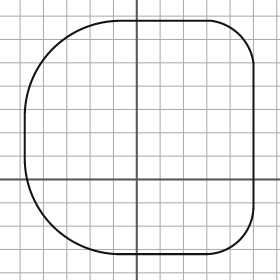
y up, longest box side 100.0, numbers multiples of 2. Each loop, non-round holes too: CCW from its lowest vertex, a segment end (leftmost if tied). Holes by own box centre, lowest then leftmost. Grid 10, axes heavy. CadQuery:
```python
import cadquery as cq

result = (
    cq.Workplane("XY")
    .moveTo(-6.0, -32.0)
    .lineTo(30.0, -32.0)
    .threePointArc((44.0, -26.0), (50.0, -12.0))
    .lineTo(50.0, 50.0)
    .threePointArc((44.0, 62.0), (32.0, 68.0))
    .lineTo(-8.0, 68.0)
    .threePointArc((-36.0, 56.0), (-48.0, 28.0))
    .lineTo(-48.0, 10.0)
    .threePointArc((-36.0, -20.0), (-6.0, -32.0))
    .close()
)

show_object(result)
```